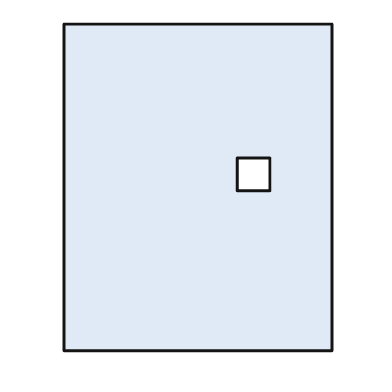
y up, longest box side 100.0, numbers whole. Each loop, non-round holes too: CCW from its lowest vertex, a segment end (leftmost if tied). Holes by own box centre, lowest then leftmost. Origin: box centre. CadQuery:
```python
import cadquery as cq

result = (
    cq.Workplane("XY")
    .moveTo(-41.0, -50.0)
    .lineTo(41.0, -50.0)
    .lineTo(41.0, 50.0)
    .lineTo(-41.0, 50.0)
    .close()
    .moveTo(12.0, -1.0)
    .lineTo(22.0, -1.0)
    .lineTo(22.0, 9.0)
    .lineTo(12.0, 9.0)
    .close()
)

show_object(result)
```